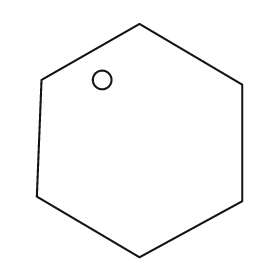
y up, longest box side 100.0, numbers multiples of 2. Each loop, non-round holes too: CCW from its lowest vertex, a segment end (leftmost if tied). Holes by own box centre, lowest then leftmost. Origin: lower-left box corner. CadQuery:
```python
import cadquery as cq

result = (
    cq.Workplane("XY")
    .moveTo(44.0, 0.0)
    .lineTo(88.0, 24.0)
    .lineTo(88.0, 74.0)
    .lineTo(44.0, 100.0)
    .lineTo(2.0, 76.0)
    .lineTo(0.0, 26.0)
    .close()
    .moveTo(28.0, 76.0)
    .circle(4.0)
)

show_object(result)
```